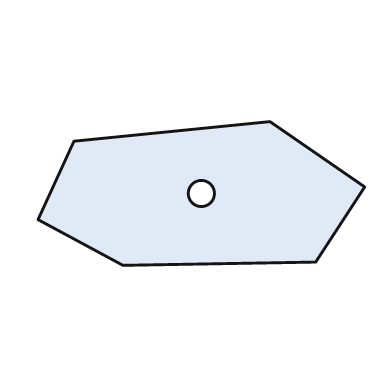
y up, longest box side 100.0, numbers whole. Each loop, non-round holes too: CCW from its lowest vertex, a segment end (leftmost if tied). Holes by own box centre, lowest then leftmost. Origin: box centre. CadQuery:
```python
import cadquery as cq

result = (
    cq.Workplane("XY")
    .moveTo(-24.0, -22.0)
    .lineTo(35.0, -21.0)
    .lineTo(50.0, 2.0)
    .lineTo(21.0, 22.0)
    .lineTo(-39.0, 16.0)
    .lineTo(-50.0, -8.0)
    .close()
    .moveTo(0.0, 0.0)
    .circle(4.0)
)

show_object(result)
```